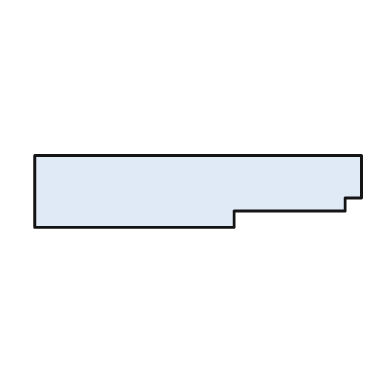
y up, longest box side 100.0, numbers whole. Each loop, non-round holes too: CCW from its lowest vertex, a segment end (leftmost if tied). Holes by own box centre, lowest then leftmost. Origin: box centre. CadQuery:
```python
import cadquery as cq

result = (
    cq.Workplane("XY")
    .moveTo(-50.0, -11.0)
    .lineTo(11.0, -11.0)
    .lineTo(11.0, -6.0)
    .lineTo(45.0, -6.0)
    .lineTo(45.0, -2.0)
    .lineTo(50.0, -2.0)
    .lineTo(50.0, 11.0)
    .lineTo(-50.0, 11.0)
    .close()
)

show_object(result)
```